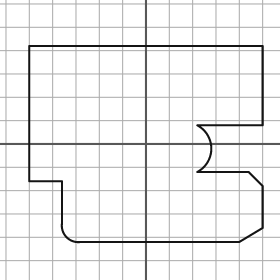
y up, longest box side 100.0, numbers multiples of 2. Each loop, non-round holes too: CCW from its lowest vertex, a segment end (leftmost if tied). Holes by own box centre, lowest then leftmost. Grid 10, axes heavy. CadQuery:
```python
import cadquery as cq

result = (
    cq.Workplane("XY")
    .moveTo(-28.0, -42.0)
    .lineTo(40.0, -42.0)
    .lineTo(50.0, -36.0)
    .lineTo(50.0, -18.0)
    .lineTo(44.0, -12.0)
    .lineTo(22.0, -12.0)
    .threePointArc((28.0, -2.0), (22.0, 8.0))
    .lineTo(50.0, 8.0)
    .lineTo(50.0, 42.0)
    .lineTo(-50.0, 42.0)
    .lineTo(-50.0, -16.0)
    .lineTo(-36.0, -16.0)
    .lineTo(-36.0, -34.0)
    .threePointArc((-34.0, -40.0), (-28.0, -42.0))
    .close()
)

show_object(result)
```